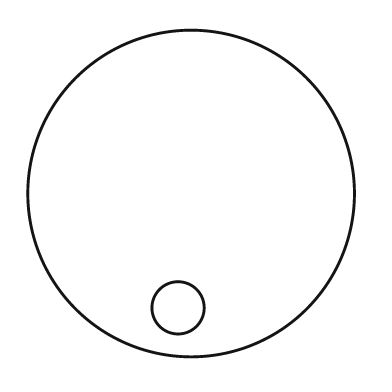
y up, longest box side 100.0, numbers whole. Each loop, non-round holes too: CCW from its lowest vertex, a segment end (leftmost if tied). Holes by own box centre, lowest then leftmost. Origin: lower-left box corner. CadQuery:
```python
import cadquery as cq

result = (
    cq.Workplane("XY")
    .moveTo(50.0, 50.0)
    .circle(50.0)
    .moveTo(46.0, 15.0)
    .circle(8.0)
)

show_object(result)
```